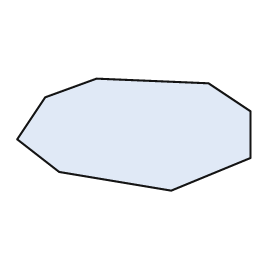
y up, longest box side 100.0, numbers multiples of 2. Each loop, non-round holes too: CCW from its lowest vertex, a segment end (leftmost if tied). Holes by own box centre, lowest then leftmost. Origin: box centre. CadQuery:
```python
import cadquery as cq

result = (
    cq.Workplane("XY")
    .moveTo(16.0, -24.0)
    .lineTo(50.0, -10.0)
    .lineTo(50.0, 10.0)
    .lineTo(32.0, 22.0)
    .lineTo(-16.0, 24.0)
    .lineTo(-38.0, 16.0)
    .lineTo(-50.0, -2.0)
    .lineTo(-32.0, -16.0)
    .close()
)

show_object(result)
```